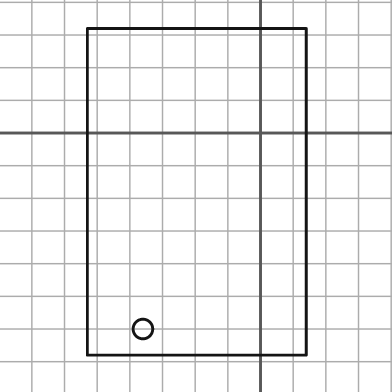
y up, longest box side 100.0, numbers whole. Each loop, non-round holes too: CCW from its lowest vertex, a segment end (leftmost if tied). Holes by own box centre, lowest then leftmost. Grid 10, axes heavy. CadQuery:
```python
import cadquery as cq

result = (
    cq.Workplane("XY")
    .moveTo(-53.0, -68.0)
    .lineTo(14.0, -68.0)
    .lineTo(14.0, 32.0)
    .lineTo(-53.0, 32.0)
    .close()
    .moveTo(-36.0, -60.0)
    .circle(3.0)
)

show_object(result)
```